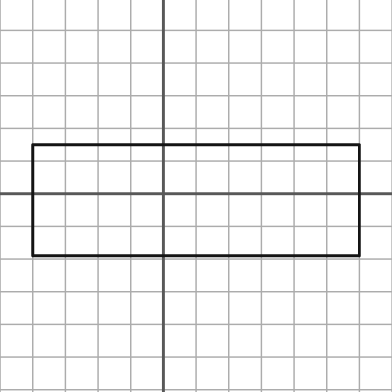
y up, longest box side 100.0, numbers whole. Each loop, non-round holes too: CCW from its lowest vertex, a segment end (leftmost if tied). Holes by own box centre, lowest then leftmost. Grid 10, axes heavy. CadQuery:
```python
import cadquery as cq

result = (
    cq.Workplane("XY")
    .moveTo(-40.0, -19.0)
    .lineTo(60.0, -19.0)
    .lineTo(60.0, 15.0)
    .lineTo(-40.0, 15.0)
    .close()
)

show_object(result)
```